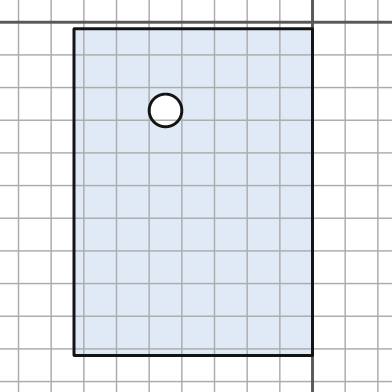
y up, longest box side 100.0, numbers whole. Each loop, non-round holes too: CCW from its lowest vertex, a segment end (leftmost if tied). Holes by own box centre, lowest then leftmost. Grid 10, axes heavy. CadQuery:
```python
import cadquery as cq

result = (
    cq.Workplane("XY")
    .moveTo(-73.0, -102.0)
    .lineTo(0.0, -102.0)
    .lineTo(0.0, -2.0)
    .lineTo(-73.0, -2.0)
    .close()
    .moveTo(-45.0, -27.0)
    .circle(5.0)
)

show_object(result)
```